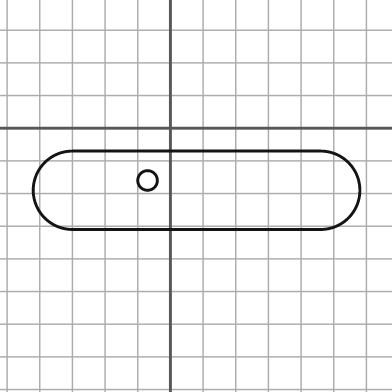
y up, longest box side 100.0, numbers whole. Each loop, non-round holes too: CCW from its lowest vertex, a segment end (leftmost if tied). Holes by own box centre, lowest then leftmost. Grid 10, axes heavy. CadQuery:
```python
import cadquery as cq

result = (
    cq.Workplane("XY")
    .moveTo(-30.0, -31.0)
    .lineTo(46.0, -31.0)
    .threePointArc((58.0, -19.0), (46.0, -7.0))
    .lineTo(-30.0, -7.0)
    .threePointArc((-42.0, -19.0), (-30.0, -31.0))
    .close()
    .moveTo(-7.0, -16.0)
    .circle(3.0)
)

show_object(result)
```